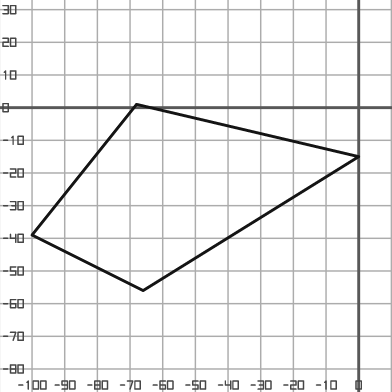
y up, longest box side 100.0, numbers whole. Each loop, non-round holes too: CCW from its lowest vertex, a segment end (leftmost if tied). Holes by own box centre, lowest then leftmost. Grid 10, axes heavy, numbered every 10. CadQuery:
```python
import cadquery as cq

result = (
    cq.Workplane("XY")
    .moveTo(-66.0, -56.0)
    .lineTo(0.0, -15.0)
    .lineTo(-68.0, 1.0)
    .lineTo(-100.0, -39.0)
    .close()
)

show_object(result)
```